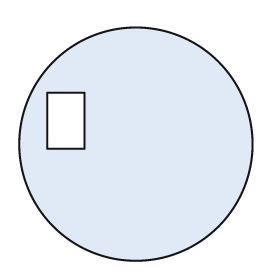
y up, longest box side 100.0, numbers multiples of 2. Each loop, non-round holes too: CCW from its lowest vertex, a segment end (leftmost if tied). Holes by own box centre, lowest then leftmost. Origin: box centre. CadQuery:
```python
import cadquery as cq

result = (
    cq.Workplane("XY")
    .moveTo(0.0, 0.0)
    .circle(50.0)
    .moveTo(-38.0, -2.0)
    .lineTo(-22.0, -2.0)
    .lineTo(-22.0, 22.0)
    .lineTo(-38.0, 22.0)
    .close()
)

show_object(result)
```